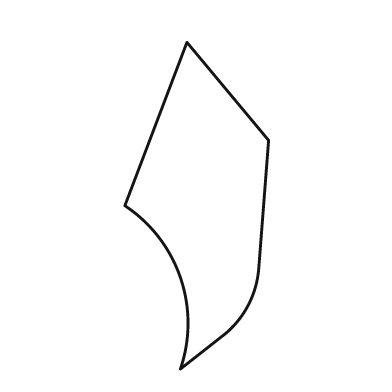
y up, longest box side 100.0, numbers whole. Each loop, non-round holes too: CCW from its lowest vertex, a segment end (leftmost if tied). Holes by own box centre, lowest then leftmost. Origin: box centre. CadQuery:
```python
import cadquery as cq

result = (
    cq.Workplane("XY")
    .moveTo(-5.0, -50.0)
    .lineTo(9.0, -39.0)
    .threePointArc((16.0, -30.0), (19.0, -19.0))
    .lineTo(22.0, 20.0)
    .lineTo(-3.0, 50.0)
    .lineTo(-22.0, 0.0)
    .threePointArc((-5.0, -22.0), (-5.0, -50.0))
    .close()
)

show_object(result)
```